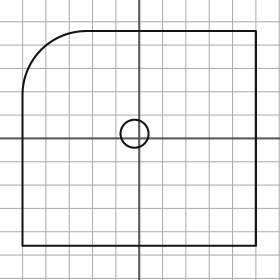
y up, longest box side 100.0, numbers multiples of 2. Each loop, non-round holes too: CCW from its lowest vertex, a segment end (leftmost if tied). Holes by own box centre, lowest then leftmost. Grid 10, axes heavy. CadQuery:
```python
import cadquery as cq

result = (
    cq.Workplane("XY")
    .moveTo(-50.0, -46.0)
    .lineTo(50.0, -46.0)
    .lineTo(50.0, 46.0)
    .lineTo(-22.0, 46.0)
    .threePointArc((-42.0, 38.0), (-50.0, 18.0))
    .close()
    .moveTo(-2.0, 2.0)
    .circle(6.0)
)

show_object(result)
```